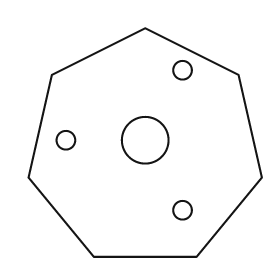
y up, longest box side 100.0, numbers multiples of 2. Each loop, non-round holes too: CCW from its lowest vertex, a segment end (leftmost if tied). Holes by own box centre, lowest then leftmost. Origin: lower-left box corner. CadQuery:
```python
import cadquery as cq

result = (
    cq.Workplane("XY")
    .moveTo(28.0, 0.0)
    .lineTo(72.0, 0.0)
    .lineTo(100.0, 34.0)
    .lineTo(90.0, 78.0)
    .lineTo(50.0, 98.0)
    .lineTo(10.0, 78.0)
    .lineTo(0.0, 34.0)
    .close()
    .moveTo(66.0, 20.0)
    .circle(4.0)
    .moveTo(16.0, 50.0)
    .circle(4.0)
    .moveTo(50.0, 50.0)
    .circle(10.0)
    .moveTo(66.0, 80.0)
    .circle(4.0)
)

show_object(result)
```